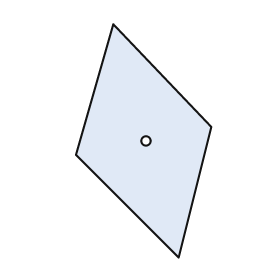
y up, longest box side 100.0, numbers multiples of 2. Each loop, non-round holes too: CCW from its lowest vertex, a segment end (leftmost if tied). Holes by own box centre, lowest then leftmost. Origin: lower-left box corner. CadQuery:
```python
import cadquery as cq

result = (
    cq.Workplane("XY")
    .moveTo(44.0, 0.0)
    .lineTo(58.0, 56.0)
    .lineTo(16.0, 100.0)
    .lineTo(0.0, 44.0)
    .close()
    .moveTo(30.0, 50.0)
    .circle(2.0)
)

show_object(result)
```